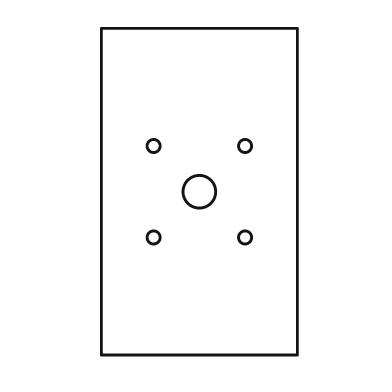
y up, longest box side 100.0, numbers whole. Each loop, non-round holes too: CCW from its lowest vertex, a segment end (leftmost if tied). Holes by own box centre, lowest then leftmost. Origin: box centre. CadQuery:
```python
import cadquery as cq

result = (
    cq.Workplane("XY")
    .moveTo(-30.0, -50.0)
    .lineTo(30.0, -50.0)
    .lineTo(30.0, 50.0)
    .lineTo(-30.0, 50.0)
    .close()
    .moveTo(-14.0, -14.0)
    .circle(2.0)
    .moveTo(14.0, -14.0)
    .circle(2.0)
    .moveTo(0.0, 0.0)
    .circle(5.0)
    .moveTo(-14.0, 14.0)
    .circle(2.0)
    .moveTo(14.0, 14.0)
    .circle(2.0)
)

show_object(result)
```